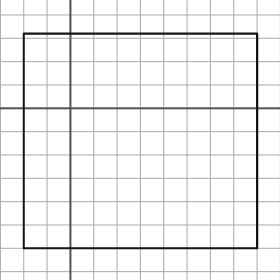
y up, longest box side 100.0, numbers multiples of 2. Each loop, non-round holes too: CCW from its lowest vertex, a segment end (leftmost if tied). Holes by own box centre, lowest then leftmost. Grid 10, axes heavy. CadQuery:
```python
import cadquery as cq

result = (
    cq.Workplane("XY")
    .moveTo(-20.0, -60.0)
    .lineTo(80.0, -60.0)
    .lineTo(80.0, 32.0)
    .lineTo(-20.0, 32.0)
    .close()
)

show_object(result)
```